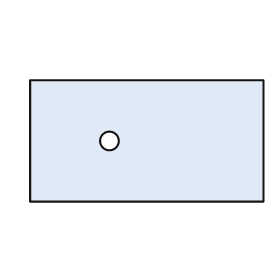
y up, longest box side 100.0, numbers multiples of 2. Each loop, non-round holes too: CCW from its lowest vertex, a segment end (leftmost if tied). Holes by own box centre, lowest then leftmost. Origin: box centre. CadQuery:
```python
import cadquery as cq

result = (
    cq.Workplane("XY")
    .moveTo(-50.0, -26.0)
    .lineTo(50.0, -26.0)
    .lineTo(50.0, 26.0)
    .lineTo(-50.0, 26.0)
    .close()
    .moveTo(-16.0, 0.0)
    .circle(4.0)
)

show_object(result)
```